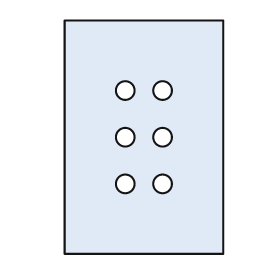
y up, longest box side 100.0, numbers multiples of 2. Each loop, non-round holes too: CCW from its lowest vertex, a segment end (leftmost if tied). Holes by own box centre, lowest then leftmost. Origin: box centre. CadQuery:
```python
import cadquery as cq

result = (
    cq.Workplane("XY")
    .moveTo(-34.0, -50.0)
    .lineTo(34.0, -50.0)
    .lineTo(34.0, 50.0)
    .lineTo(-34.0, 50.0)
    .close()
    .moveTo(-8.0, -20.0)
    .circle(4.0)
    .moveTo(8.0, -20.0)
    .circle(4.0)
    .moveTo(-8.0, 0.0)
    .circle(4.0)
    .moveTo(8.0, 0.0)
    .circle(4.0)
    .moveTo(-8.0, 20.0)
    .circle(4.0)
    .moveTo(8.0, 20.0)
    .circle(4.0)
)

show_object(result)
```